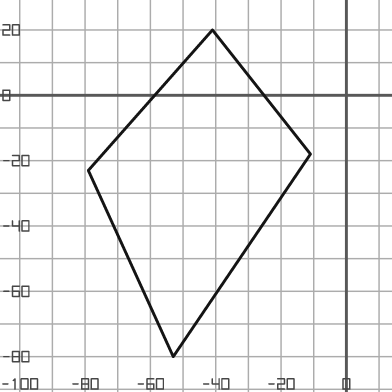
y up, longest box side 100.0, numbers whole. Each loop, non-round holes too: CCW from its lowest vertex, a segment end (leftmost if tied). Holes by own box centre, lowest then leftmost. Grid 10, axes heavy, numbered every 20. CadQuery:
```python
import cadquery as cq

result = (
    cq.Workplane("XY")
    .moveTo(-53.0, -80.0)
    .lineTo(-11.0, -18.0)
    .lineTo(-41.0, 20.0)
    .lineTo(-79.0, -23.0)
    .close()
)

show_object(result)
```